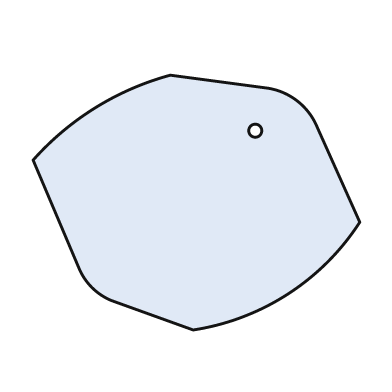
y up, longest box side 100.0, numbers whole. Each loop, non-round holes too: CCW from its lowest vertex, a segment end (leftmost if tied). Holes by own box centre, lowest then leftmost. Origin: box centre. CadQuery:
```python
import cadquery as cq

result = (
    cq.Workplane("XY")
    .moveTo(-1.0, -39.0)
    .threePointArc((28.0, -28.0), (50.0, -6.0))
    .lineTo(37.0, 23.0)
    .threePointArc((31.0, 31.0), (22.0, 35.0))
    .lineTo(-8.0, 39.0)
    .threePointArc((-31.0, 29.0), (-50.0, 13.0))
    .lineTo(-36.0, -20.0)
    .threePointArc((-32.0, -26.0), (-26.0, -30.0))
    .close()
    .moveTo(18.0, 22.0)
    .circle(2.0)
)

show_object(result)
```